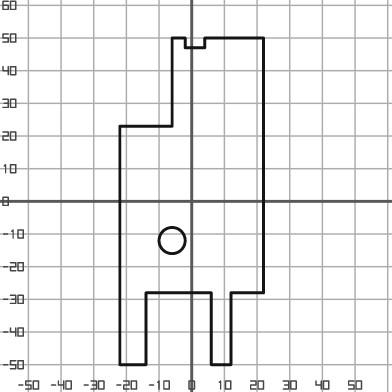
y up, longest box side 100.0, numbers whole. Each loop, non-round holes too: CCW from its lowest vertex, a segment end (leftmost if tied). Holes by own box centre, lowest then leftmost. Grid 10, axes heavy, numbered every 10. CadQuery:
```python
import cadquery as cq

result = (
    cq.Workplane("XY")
    .moveTo(-22.0, -50.0)
    .lineTo(-14.0, -50.0)
    .lineTo(-14.0, -28.0)
    .lineTo(6.0, -28.0)
    .lineTo(6.0, -50.0)
    .lineTo(12.0, -50.0)
    .lineTo(12.0, -28.0)
    .lineTo(22.0, -28.0)
    .lineTo(22.0, 50.0)
    .lineTo(4.0, 50.0)
    .lineTo(4.0, 47.0)
    .lineTo(-2.0, 47.0)
    .lineTo(-2.0, 50.0)
    .lineTo(-6.0, 50.0)
    .lineTo(-6.0, 23.0)
    .lineTo(-22.0, 23.0)
    .close()
    .moveTo(-6.0, -12.0)
    .circle(4.0)
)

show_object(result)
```